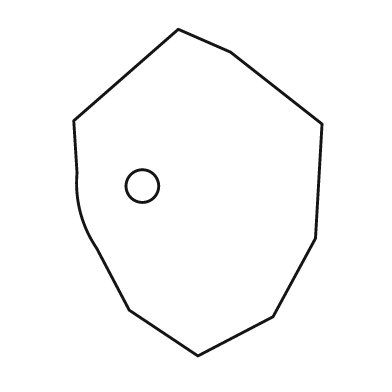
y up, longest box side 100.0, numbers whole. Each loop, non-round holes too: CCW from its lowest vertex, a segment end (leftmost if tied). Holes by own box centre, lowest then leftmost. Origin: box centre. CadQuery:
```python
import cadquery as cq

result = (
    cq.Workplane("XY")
    .moveTo(0.0, -50.0)
    .lineTo(23.0, -38.0)
    .lineTo(36.0, -14.0)
    .lineTo(38.0, 21.0)
    .lineTo(10.0, 43.0)
    .lineTo(-6.0, 50.0)
    .lineTo(-38.0, 22.0)
    .lineTo(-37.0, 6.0)
    .threePointArc((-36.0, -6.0), (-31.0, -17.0))
    .lineTo(-21.0, -36.0)
    .close()
    .moveTo(-17.0, 2.0)
    .circle(5.0)
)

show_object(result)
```